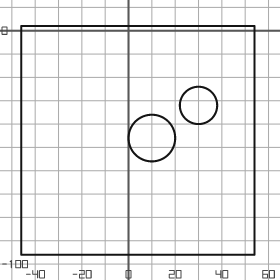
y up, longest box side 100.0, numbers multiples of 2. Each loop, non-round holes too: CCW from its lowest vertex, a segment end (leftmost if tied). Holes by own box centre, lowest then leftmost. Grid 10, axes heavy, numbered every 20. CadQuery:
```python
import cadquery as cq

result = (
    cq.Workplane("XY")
    .moveTo(-46.0, -96.0)
    .lineTo(54.0, -96.0)
    .lineTo(54.0, 2.0)
    .lineTo(-46.0, 2.0)
    .close()
    .moveTo(10.0, -46.0)
    .circle(10.0)
    .moveTo(30.0, -32.0)
    .circle(8.0)
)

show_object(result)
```